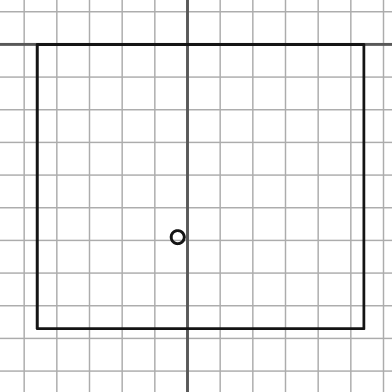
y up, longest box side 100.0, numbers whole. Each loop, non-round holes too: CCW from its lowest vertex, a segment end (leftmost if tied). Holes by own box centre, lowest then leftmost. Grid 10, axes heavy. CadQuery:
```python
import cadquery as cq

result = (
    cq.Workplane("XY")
    .moveTo(-46.0, -87.0)
    .lineTo(54.0, -87.0)
    .lineTo(54.0, 0.0)
    .lineTo(-46.0, 0.0)
    .close()
    .moveTo(-3.0, -59.0)
    .circle(2.0)
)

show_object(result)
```